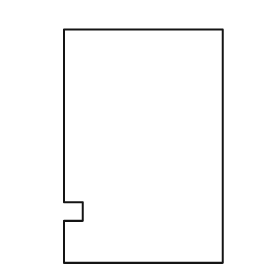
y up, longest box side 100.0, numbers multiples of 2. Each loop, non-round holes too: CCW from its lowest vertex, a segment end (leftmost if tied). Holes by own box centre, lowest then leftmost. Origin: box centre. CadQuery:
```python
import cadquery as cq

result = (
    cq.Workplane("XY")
    .moveTo(-34.0, -50.0)
    .lineTo(34.0, -50.0)
    .lineTo(34.0, 50.0)
    .lineTo(-34.0, 50.0)
    .lineTo(-34.0, -24.0)
    .lineTo(-26.0, -24.0)
    .lineTo(-26.0, -32.0)
    .lineTo(-34.0, -32.0)
    .close()
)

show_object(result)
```